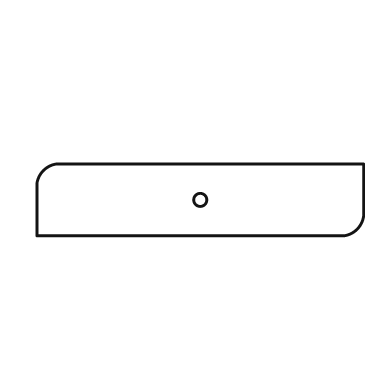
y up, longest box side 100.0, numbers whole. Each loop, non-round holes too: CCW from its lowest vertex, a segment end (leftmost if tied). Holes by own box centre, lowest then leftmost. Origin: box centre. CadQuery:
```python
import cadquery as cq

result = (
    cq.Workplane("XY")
    .moveTo(-50.0, -11.0)
    .lineTo(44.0, -11.0)
    .threePointArc((48.0, -9.0), (50.0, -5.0))
    .lineTo(50.0, 11.0)
    .lineTo(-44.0, 11.0)
    .threePointArc((-48.0, 9.0), (-50.0, 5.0))
    .close()
    .moveTo(0.0, 0.0)
    .circle(2.0)
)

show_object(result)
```